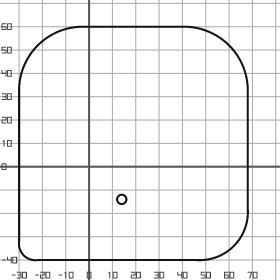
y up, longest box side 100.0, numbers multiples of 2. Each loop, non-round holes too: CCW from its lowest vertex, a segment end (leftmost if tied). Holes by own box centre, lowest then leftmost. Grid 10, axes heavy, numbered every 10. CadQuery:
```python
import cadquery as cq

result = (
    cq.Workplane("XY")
    .moveTo(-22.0, -40.0)
    .lineTo(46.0, -40.0)
    .threePointArc((62.0, -34.0), (68.0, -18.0))
    .lineTo(68.0, 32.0)
    .threePointArc((60.0, 52.0), (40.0, 60.0))
    .lineTo(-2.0, 60.0)
    .threePointArc((-22.0, 52.0), (-30.0, 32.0))
    .lineTo(-30.0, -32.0)
    .threePointArc((-28.0, -38.0), (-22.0, -40.0))
    .close()
    .moveTo(14.0, -14.0)
    .circle(2.0)
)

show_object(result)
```